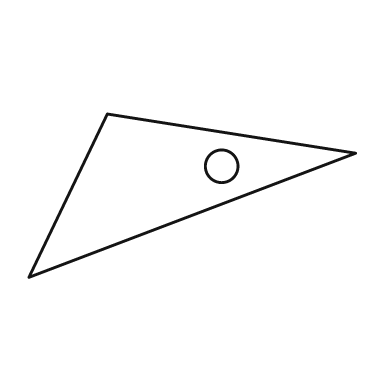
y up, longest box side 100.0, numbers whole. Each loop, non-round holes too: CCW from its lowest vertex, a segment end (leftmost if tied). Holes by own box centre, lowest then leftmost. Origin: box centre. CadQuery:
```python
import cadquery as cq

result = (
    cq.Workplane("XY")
    .moveTo(-50.0, -25.0)
    .lineTo(50.0, 13.0)
    .lineTo(-26.0, 25.0)
    .close()
    .moveTo(9.0, 9.0)
    .circle(5.0)
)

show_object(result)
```